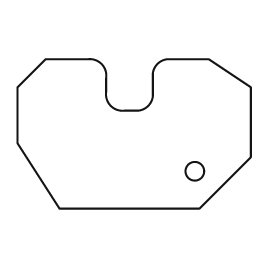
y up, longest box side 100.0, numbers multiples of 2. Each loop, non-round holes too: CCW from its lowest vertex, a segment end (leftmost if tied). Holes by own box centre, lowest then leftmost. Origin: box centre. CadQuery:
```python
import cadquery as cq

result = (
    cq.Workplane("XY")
    .moveTo(-32.0, -32.0)
    .lineTo(28.0, -32.0)
    .lineTo(50.0, -10.0)
    .lineTo(50.0, 20.0)
    .lineTo(32.0, 32.0)
    .lineTo(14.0, 32.0)
    .threePointArc((10.0, 30.0), (8.0, 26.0))
    .lineTo(8.0, 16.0)
    .threePointArc((6.0, 12.0), (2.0, 10.0))
    .lineTo(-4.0, 10.0)
    .threePointArc((-10.0, 12.0), (-12.0, 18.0))
    .lineTo(-12.0, 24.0)
    .threePointArc((-14.0, 30.0), (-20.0, 32.0))
    .lineTo(-38.0, 32.0)
    .lineTo(-50.0, 20.0)
    .lineTo(-50.0, -4.0)
    .close()
    .moveTo(26.0, -16.0)
    .circle(4.0)
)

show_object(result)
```